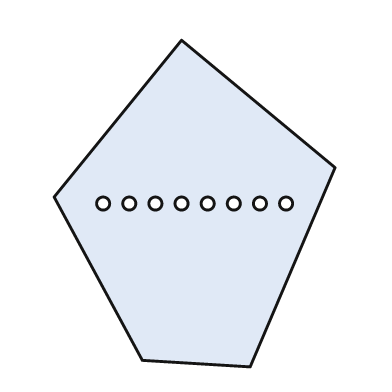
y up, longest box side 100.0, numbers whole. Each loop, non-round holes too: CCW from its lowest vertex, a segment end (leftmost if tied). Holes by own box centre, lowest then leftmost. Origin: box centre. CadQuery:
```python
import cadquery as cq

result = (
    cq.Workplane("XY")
    .moveTo(17.0, -50.0)
    .lineTo(43.0, 11.0)
    .lineTo(-4.0, 50.0)
    .lineTo(-43.0, 2.0)
    .lineTo(-16.0, -48.0)
    .close()
    .moveTo(-28.0, 0.0)
    .circle(2.0)
    .moveTo(-20.0, 0.0)
    .circle(2.0)
    .moveTo(-12.0, 0.0)
    .circle(2.0)
    .moveTo(-4.0, 0.0)
    .circle(2.0)
    .moveTo(4.0, 0.0)
    .circle(2.0)
    .moveTo(12.0, 0.0)
    .circle(2.0)
    .moveTo(20.0, 0.0)
    .circle(2.0)
    .moveTo(28.0, 0.0)
    .circle(2.0)
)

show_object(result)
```